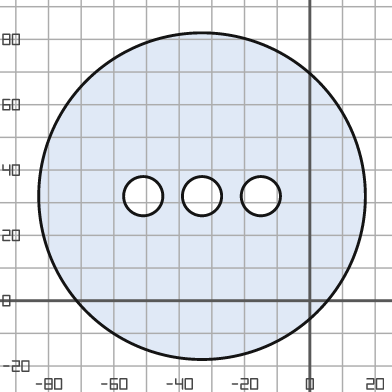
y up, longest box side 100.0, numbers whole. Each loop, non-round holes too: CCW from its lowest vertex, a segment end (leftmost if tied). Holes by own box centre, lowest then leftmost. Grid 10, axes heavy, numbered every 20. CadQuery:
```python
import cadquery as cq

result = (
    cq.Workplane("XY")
    .moveTo(-33.0, 32.0)
    .circle(50.0)
    .moveTo(-51.0, 32.0)
    .circle(6.0)
    .moveTo(-33.0, 32.0)
    .circle(6.0)
    .moveTo(-15.0, 32.0)
    .circle(6.0)
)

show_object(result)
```